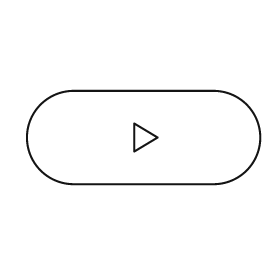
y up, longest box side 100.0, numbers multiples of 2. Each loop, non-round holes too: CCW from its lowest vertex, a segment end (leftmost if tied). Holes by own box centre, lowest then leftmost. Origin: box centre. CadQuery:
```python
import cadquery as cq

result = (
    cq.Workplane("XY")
    .moveTo(-30.0, -20.0)
    .lineTo(30.0, -20.0)
    .threePointArc((50.0, 0.0), (30.0, 20.0))
    .lineTo(-30.0, 20.0)
    .threePointArc((-50.0, 0.0), (-30.0, -20.0))
    .close()
    .moveTo(-4.0, -6.0)
    .lineTo(6.0, 0.0)
    .lineTo(-4.0, 6.0)
    .close()
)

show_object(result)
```